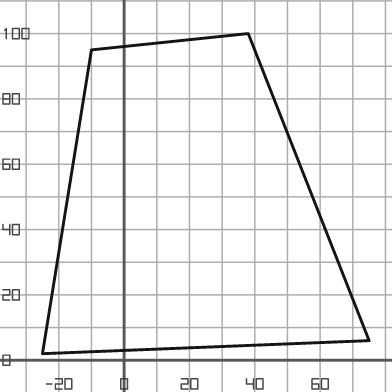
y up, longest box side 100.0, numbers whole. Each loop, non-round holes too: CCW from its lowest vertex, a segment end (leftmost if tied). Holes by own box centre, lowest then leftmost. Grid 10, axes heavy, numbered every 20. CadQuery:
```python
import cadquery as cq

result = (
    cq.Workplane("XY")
    .moveTo(-25.0, 2.0)
    .lineTo(75.0, 6.0)
    .lineTo(38.0, 100.0)
    .lineTo(-10.0, 95.0)
    .close()
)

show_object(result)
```